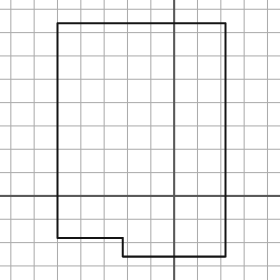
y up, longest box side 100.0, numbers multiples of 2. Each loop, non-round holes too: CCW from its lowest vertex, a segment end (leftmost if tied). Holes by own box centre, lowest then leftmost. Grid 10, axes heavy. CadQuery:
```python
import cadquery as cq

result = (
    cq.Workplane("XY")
    .moveTo(-22.0, -26.0)
    .lineTo(22.0, -26.0)
    .lineTo(22.0, 74.0)
    .lineTo(-50.0, 74.0)
    .lineTo(-50.0, -18.0)
    .lineTo(-22.0, -18.0)
    .close()
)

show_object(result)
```